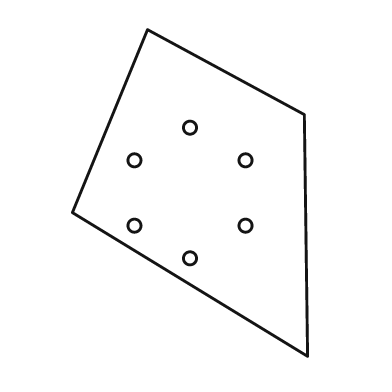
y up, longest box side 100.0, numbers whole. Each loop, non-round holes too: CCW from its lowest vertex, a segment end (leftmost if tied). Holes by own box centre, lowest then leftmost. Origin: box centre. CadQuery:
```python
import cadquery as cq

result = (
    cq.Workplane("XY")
    .moveTo(36.0, -50.0)
    .lineTo(35.0, 24.0)
    .lineTo(-13.0, 50.0)
    .lineTo(-36.0, -6.0)
    .close()
    .moveTo(0.0, -20.0)
    .circle(2.0)
    .moveTo(-17.0, -10.0)
    .circle(2.0)
    .moveTo(17.0, -10.0)
    .circle(2.0)
    .moveTo(-17.0, 10.0)
    .circle(2.0)
    .moveTo(17.0, 10.0)
    .circle(2.0)
    .moveTo(0.0, 20.0)
    .circle(2.0)
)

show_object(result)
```